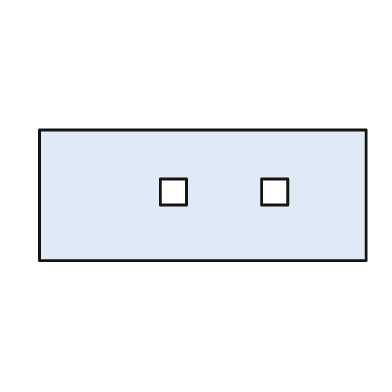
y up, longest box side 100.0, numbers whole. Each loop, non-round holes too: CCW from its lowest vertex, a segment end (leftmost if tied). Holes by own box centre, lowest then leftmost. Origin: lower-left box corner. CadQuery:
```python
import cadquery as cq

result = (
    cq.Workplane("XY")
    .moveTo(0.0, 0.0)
    .lineTo(100.0, 0.0)
    .lineTo(100.0, 40.0)
    .lineTo(0.0, 40.0)
    .close()
    .moveTo(37.0, 17.0)
    .lineTo(45.0, 17.0)
    .lineTo(45.0, 25.0)
    .lineTo(37.0, 25.0)
    .close()
    .moveTo(68.0, 17.0)
    .lineTo(76.0, 17.0)
    .lineTo(76.0, 25.0)
    .lineTo(68.0, 25.0)
    .close()
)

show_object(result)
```